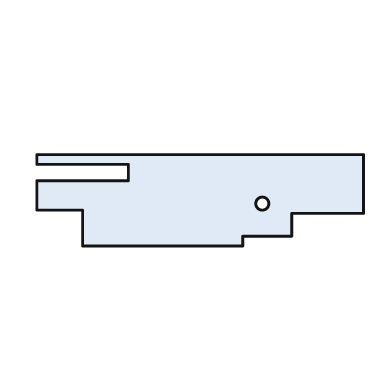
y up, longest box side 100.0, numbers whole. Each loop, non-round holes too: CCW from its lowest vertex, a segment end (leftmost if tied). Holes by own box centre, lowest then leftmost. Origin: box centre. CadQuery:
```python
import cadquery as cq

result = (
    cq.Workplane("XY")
    .moveTo(-36.0, -14.0)
    .lineTo(13.0, -14.0)
    .lineTo(13.0, -11.0)
    .lineTo(28.0, -11.0)
    .lineTo(28.0, -4.0)
    .lineTo(50.0, -4.0)
    .lineTo(50.0, 14.0)
    .lineTo(-50.0, 14.0)
    .lineTo(-50.0, 11.0)
    .lineTo(-22.0, 11.0)
    .lineTo(-22.0, 6.0)
    .lineTo(-50.0, 6.0)
    .lineTo(-50.0, -3.0)
    .lineTo(-36.0, -3.0)
    .close()
    .moveTo(19.0, -1.0)
    .circle(2.0)
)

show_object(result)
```